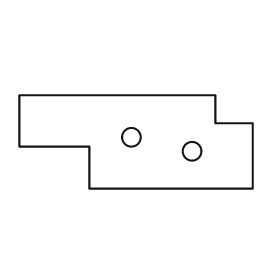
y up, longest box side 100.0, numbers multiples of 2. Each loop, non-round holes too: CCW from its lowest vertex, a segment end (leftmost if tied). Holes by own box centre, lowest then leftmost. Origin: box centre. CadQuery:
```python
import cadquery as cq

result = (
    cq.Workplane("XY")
    .moveTo(-20.0, -20.0)
    .lineTo(50.0, -20.0)
    .lineTo(50.0, 8.0)
    .lineTo(34.0, 8.0)
    .lineTo(34.0, 20.0)
    .lineTo(-50.0, 20.0)
    .lineTo(-50.0, -2.0)
    .lineTo(-20.0, -2.0)
    .close()
    .moveTo(24.0, -4.0)
    .circle(4.0)
    .moveTo(-2.0, 2.0)
    .circle(4.0)
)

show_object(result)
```